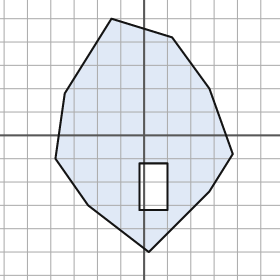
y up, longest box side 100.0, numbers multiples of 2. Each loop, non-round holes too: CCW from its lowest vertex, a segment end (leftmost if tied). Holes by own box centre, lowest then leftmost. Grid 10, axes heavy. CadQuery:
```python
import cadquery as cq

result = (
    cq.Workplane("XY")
    .moveTo(2.0, -50.0)
    .lineTo(28.0, -24.0)
    .lineTo(38.0, -8.0)
    .lineTo(28.0, 20.0)
    .lineTo(12.0, 42.0)
    .lineTo(-14.0, 50.0)
    .lineTo(-34.0, 18.0)
    .lineTo(-38.0, -10.0)
    .lineTo(-24.0, -30.0)
    .close()
    .moveTo(-2.0, -32.0)
    .lineTo(10.0, -32.0)
    .lineTo(10.0, -12.0)
    .lineTo(-2.0, -12.0)
    .close()
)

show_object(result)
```